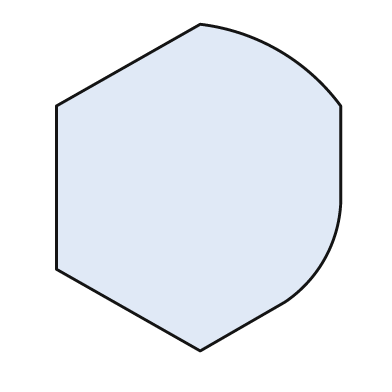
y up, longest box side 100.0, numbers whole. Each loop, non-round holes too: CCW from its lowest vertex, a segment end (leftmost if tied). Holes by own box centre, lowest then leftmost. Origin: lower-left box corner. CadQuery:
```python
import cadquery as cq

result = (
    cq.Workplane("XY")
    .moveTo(44.0, 0.0)
    .lineTo(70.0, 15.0)
    .threePointArc((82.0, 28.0), (87.0, 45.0))
    .lineTo(87.0, 75.0)
    .threePointArc((68.0, 92.0), (44.0, 100.0))
    .lineTo(0.0, 75.0)
    .lineTo(0.0, 25.0)
    .close()
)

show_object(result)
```